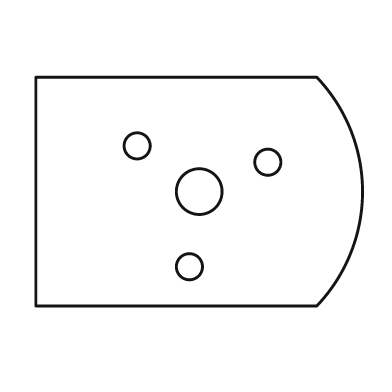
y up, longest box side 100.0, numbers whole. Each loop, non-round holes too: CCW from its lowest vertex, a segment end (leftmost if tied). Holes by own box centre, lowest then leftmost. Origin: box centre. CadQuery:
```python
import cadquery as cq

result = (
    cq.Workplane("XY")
    .moveTo(-50.0, -35.0)
    .lineTo(36.0, -35.0)
    .threePointArc((50.0, 0.0), (36.0, 35.0))
    .lineTo(-50.0, 35.0)
    .close()
    .moveTo(-3.0, -23.0)
    .circle(4.0)
    .moveTo(0.0, 0.0)
    .circle(7.0)
    .moveTo(21.0, 9.0)
    .circle(4.0)
    .moveTo(-19.0, 14.0)
    .circle(4.0)
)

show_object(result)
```